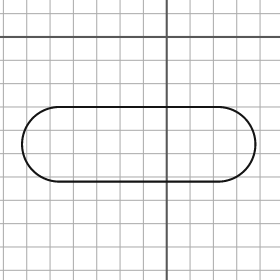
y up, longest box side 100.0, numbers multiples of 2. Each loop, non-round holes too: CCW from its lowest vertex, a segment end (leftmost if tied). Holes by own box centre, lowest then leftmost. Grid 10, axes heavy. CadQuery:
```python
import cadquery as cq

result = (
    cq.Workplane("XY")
    .moveTo(-46.0, -62.0)
    .lineTo(22.0, -62.0)
    .threePointArc((38.0, -46.0), (22.0, -30.0))
    .lineTo(-46.0, -30.0)
    .threePointArc((-62.0, -46.0), (-46.0, -62.0))
    .close()
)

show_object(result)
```